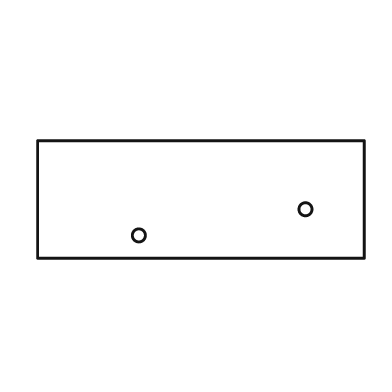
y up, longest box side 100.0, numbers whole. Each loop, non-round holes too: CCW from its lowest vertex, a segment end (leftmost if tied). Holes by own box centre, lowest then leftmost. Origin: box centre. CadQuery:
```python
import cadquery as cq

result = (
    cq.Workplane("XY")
    .moveTo(-50.0, -18.0)
    .lineTo(50.0, -18.0)
    .lineTo(50.0, 18.0)
    .lineTo(-50.0, 18.0)
    .close()
    .moveTo(-19.0, -11.0)
    .circle(2.0)
    .moveTo(32.0, -3.0)
    .circle(2.0)
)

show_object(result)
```